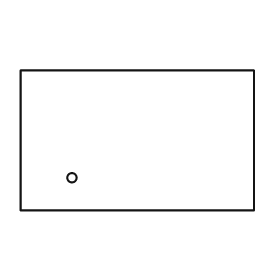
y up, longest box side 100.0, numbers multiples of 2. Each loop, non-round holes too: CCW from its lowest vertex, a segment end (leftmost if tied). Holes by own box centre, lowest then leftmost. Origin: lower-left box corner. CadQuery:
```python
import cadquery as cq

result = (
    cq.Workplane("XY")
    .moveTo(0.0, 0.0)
    .lineTo(100.0, 0.0)
    .lineTo(100.0, 60.0)
    .lineTo(0.0, 60.0)
    .close()
    .moveTo(22.0, 14.0)
    .circle(2.0)
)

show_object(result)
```